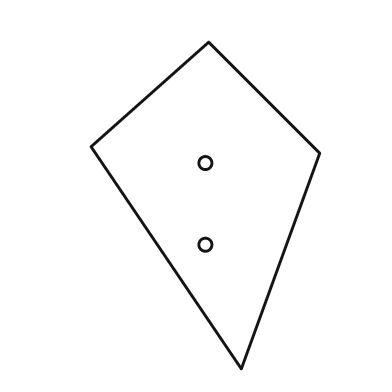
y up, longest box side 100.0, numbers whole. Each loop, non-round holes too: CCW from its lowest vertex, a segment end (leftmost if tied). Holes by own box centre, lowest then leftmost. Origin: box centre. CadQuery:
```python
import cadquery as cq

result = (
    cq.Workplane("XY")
    .moveTo(11.0, -50.0)
    .lineTo(35.0, 16.0)
    .lineTo(1.0, 50.0)
    .lineTo(-35.0, 18.0)
    .close()
    .moveTo(0.0, -12.0)
    .circle(2.0)
    .moveTo(0.0, 13.0)
    .circle(2.0)
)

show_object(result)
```